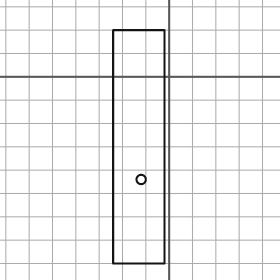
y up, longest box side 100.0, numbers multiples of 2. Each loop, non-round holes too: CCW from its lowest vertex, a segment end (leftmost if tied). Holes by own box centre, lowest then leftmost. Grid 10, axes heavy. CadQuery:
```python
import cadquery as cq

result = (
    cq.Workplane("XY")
    .moveTo(-24.0, -80.0)
    .lineTo(-2.0, -80.0)
    .lineTo(-2.0, 20.0)
    .lineTo(-24.0, 20.0)
    .close()
    .moveTo(-12.0, -44.0)
    .circle(2.0)
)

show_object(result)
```